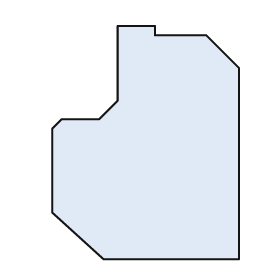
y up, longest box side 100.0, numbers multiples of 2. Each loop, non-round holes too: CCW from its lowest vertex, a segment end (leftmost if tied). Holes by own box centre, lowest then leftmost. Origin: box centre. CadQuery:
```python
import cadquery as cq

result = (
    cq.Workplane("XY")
    .moveTo(-18.0, -50.0)
    .lineTo(40.0, -50.0)
    .lineTo(40.0, 32.0)
    .lineTo(26.0, 46.0)
    .lineTo(4.0, 46.0)
    .lineTo(4.0, 50.0)
    .lineTo(-12.0, 50.0)
    .lineTo(-12.0, 18.0)
    .lineTo(-20.0, 10.0)
    .lineTo(-36.0, 10.0)
    .lineTo(-40.0, 6.0)
    .lineTo(-40.0, -30.0)
    .close()
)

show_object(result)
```